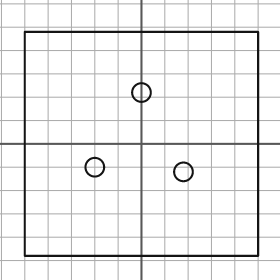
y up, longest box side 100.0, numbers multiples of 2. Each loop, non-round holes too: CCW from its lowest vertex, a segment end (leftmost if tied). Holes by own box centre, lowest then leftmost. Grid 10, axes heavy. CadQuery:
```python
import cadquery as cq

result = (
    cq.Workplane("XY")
    .moveTo(-50.0, -48.0)
    .lineTo(50.0, -48.0)
    .lineTo(50.0, 48.0)
    .lineTo(-50.0, 48.0)
    .close()
    .moveTo(18.0, -12.0)
    .circle(4.0)
    .moveTo(-20.0, -10.0)
    .circle(4.0)
    .moveTo(0.0, 22.0)
    .circle(4.0)
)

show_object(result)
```